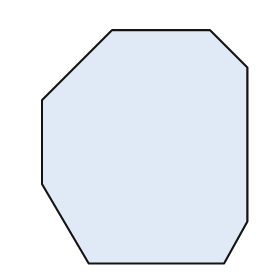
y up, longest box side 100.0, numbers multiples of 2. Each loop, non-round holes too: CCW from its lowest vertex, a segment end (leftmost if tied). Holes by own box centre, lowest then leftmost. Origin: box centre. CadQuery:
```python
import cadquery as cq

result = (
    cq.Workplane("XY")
    .moveTo(-24.0, -50.0)
    .lineTo(34.0, -50.0)
    .lineTo(44.0, -32.0)
    .lineTo(44.0, 34.0)
    .lineTo(28.0, 50.0)
    .lineTo(-14.0, 50.0)
    .lineTo(-44.0, 20.0)
    .lineTo(-44.0, -16.0)
    .close()
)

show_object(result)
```